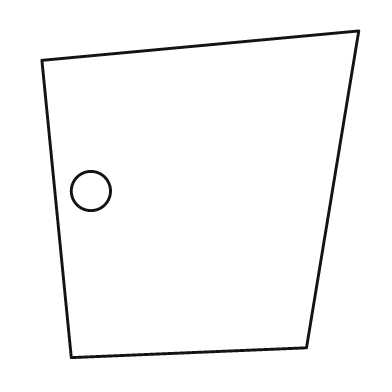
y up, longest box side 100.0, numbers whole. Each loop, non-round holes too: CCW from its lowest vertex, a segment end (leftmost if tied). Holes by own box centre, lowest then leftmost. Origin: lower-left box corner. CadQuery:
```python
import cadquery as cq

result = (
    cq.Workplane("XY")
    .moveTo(9.0, 0.0)
    .lineTo(81.0, 3.0)
    .lineTo(97.0, 100.0)
    .lineTo(0.0, 91.0)
    .close()
    .moveTo(15.0, 51.0)
    .circle(6.0)
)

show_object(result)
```